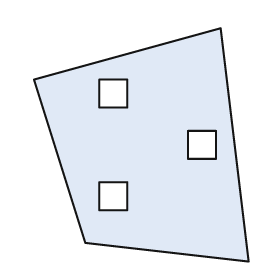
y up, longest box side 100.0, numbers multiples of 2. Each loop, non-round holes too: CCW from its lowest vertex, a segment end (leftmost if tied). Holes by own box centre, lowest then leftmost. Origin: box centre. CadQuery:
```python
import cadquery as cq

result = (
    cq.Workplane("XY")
    .moveTo(46.0, -50.0)
    .lineTo(34.0, 50.0)
    .lineTo(-46.0, 28.0)
    .lineTo(-24.0, -42.0)
    .close()
    .moveTo(-18.0, -28.0)
    .lineTo(-6.0, -28.0)
    .lineTo(-6.0, -16.0)
    .lineTo(-18.0, -16.0)
    .close()
    .moveTo(20.0, -6.0)
    .lineTo(32.0, -6.0)
    .lineTo(32.0, 6.0)
    .lineTo(20.0, 6.0)
    .close()
    .moveTo(-18.0, 16.0)
    .lineTo(-6.0, 16.0)
    .lineTo(-6.0, 28.0)
    .lineTo(-18.0, 28.0)
    .close()
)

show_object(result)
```